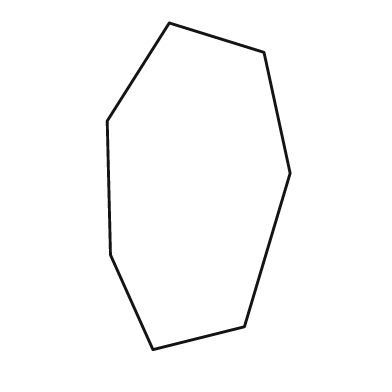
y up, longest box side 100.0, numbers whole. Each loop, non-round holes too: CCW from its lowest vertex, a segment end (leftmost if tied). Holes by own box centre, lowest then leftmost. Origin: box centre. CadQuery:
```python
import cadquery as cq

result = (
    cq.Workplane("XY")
    .moveTo(-14.0, -50.0)
    .lineTo(14.0, -43.0)
    .lineTo(28.0, 4.0)
    .lineTo(20.0, 41.0)
    .lineTo(-9.0, 50.0)
    .lineTo(-28.0, 20.0)
    .lineTo(-27.0, -21.0)
    .close()
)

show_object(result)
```